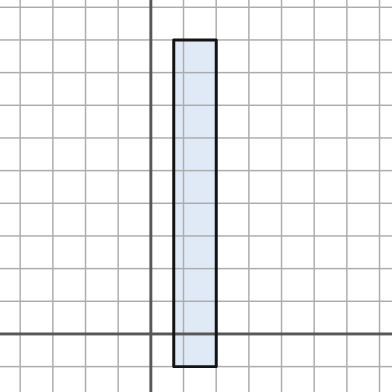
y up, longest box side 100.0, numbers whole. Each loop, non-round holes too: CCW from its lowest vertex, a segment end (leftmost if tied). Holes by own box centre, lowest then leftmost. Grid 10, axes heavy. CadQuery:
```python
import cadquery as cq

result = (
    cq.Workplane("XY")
    .moveTo(7.0, -10.0)
    .lineTo(20.0, -10.0)
    .lineTo(20.0, 90.0)
    .lineTo(7.0, 90.0)
    .close()
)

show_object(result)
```